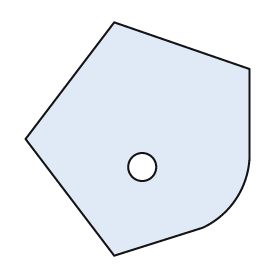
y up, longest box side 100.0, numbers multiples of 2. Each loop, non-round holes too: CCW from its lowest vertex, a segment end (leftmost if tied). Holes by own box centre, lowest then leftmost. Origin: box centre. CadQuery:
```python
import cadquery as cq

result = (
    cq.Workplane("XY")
    .moveTo(-10.0, -50.0)
    .lineTo(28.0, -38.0)
    .threePointArc((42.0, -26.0), (48.0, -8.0))
    .lineTo(48.0, 30.0)
    .lineTo(-10.0, 50.0)
    .lineTo(-48.0, 0.0)
    .close()
    .moveTo(2.0, -12.0)
    .circle(6.0)
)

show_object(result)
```